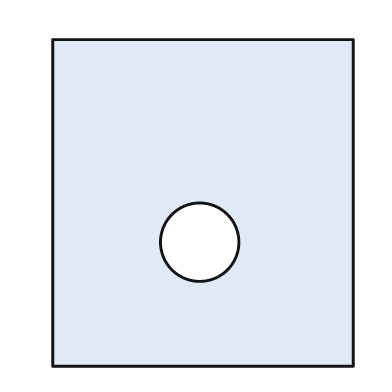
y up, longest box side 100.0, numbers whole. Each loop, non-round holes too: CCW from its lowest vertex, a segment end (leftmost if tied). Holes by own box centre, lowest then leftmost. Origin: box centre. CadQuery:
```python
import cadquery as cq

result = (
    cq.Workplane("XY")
    .moveTo(-46.0, -50.0)
    .lineTo(46.0, -50.0)
    .lineTo(46.0, 50.0)
    .lineTo(-46.0, 50.0)
    .close()
    .moveTo(-1.0, -12.0)
    .circle(12.0)
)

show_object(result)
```